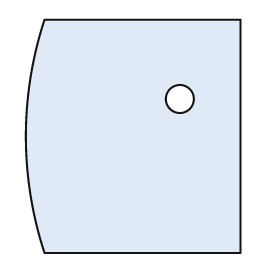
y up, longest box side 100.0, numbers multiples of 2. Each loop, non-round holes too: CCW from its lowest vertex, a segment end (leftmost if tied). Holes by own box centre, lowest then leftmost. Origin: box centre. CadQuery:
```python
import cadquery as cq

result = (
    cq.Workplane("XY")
    .moveTo(-38.0, -50.0)
    .lineTo(46.0, -50.0)
    .lineTo(46.0, 50.0)
    .lineTo(-38.0, 50.0)
    .threePointArc((-46.0, 0.0), (-38.0, -50.0))
    .close()
    .moveTo(20.0, 16.0)
    .circle(6.0)
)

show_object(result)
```